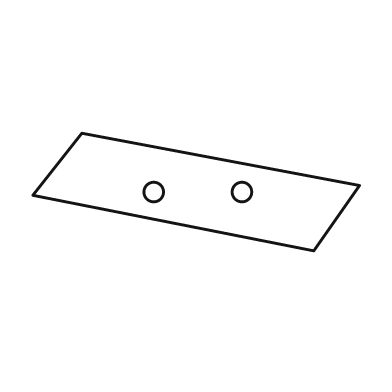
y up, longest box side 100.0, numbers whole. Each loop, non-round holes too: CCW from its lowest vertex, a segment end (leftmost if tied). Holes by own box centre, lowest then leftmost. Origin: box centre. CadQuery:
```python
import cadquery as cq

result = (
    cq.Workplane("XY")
    .moveTo(36.0, -18.0)
    .lineTo(50.0, 2.0)
    .lineTo(-35.0, 18.0)
    .lineTo(-50.0, -1.0)
    .close()
    .moveTo(-13.0, 0.0)
    .circle(3.0)
    .moveTo(14.0, 0.0)
    .circle(3.0)
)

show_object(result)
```